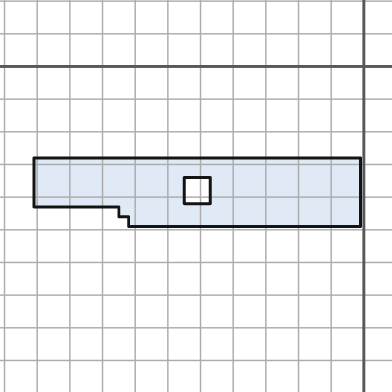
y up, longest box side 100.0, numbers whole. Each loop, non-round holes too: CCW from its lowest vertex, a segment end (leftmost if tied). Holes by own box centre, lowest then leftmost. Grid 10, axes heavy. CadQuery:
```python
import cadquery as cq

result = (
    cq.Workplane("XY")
    .moveTo(-72.0, -49.0)
    .lineTo(-1.0, -49.0)
    .lineTo(-1.0, -28.0)
    .lineTo(-101.0, -28.0)
    .lineTo(-101.0, -43.0)
    .lineTo(-75.0, -43.0)
    .lineTo(-75.0, -46.0)
    .lineTo(-72.0, -46.0)
    .close()
    .moveTo(-55.0, -42.0)
    .lineTo(-47.0, -42.0)
    .lineTo(-47.0, -34.0)
    .lineTo(-55.0, -34.0)
    .close()
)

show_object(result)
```